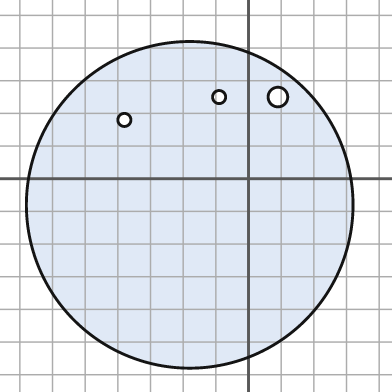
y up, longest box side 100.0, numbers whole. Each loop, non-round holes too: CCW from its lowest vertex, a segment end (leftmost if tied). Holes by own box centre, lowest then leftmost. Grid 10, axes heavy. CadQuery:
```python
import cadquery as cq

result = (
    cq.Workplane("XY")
    .moveTo(-18.0, -8.0)
    .circle(50.0)
    .moveTo(-38.0, 18.0)
    .circle(2.0)
    .moveTo(-9.0, 25.0)
    .circle(2.0)
    .moveTo(9.0, 25.0)
    .circle(3.0)
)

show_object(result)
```